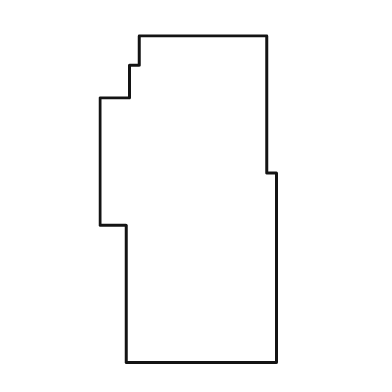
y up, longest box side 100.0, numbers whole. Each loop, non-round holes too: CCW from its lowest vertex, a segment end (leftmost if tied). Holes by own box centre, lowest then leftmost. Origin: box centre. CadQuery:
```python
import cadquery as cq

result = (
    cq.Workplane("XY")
    .moveTo(-19.0, -50.0)
    .lineTo(27.0, -50.0)
    .lineTo(27.0, 8.0)
    .lineTo(24.0, 8.0)
    .lineTo(24.0, 50.0)
    .lineTo(-15.0, 50.0)
    .lineTo(-15.0, 41.0)
    .lineTo(-18.0, 41.0)
    .lineTo(-18.0, 31.0)
    .lineTo(-27.0, 31.0)
    .lineTo(-27.0, -8.0)
    .lineTo(-19.0, -8.0)
    .close()
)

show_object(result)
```